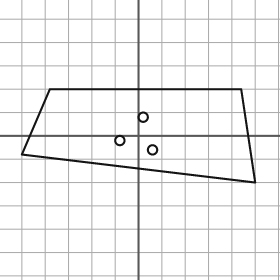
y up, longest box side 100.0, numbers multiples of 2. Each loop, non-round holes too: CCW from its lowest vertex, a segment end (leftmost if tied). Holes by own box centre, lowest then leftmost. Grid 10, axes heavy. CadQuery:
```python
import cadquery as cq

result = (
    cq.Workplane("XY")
    .moveTo(50.0, -20.0)
    .lineTo(44.0, 20.0)
    .lineTo(-38.0, 20.0)
    .lineTo(-50.0, -8.0)
    .close()
    .moveTo(6.0, -6.0)
    .circle(2.0)
    .moveTo(-8.0, -2.0)
    .circle(2.0)
    .moveTo(2.0, 8.0)
    .circle(2.0)
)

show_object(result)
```